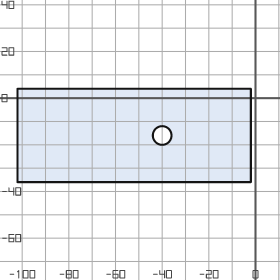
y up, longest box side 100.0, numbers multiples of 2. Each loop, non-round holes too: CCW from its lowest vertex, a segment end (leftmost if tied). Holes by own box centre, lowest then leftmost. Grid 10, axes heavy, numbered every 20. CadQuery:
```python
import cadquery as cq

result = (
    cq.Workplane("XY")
    .moveTo(-102.0, -36.0)
    .lineTo(-2.0, -36.0)
    .lineTo(-2.0, 4.0)
    .lineTo(-102.0, 4.0)
    .close()
    .moveTo(-40.0, -16.0)
    .circle(4.0)
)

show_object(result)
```